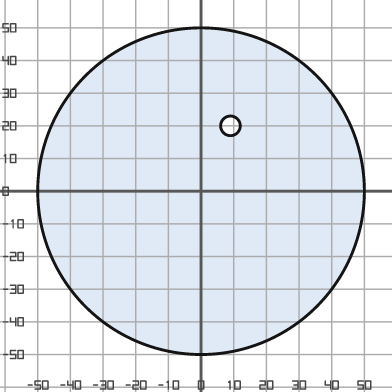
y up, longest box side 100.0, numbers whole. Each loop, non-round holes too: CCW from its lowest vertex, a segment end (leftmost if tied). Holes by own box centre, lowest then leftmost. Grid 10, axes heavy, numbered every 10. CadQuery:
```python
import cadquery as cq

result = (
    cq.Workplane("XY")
    .moveTo(0.0, 0.0)
    .circle(50.0)
    .moveTo(9.0, 20.0)
    .circle(3.0)
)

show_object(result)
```